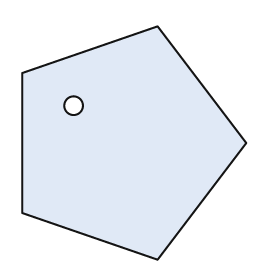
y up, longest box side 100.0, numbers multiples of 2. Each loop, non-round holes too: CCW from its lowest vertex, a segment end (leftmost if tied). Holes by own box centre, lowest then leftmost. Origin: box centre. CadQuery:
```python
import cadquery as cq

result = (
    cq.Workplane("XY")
    .moveTo(10.0, -50.0)
    .lineTo(48.0, 0.0)
    .lineTo(10.0, 50.0)
    .lineTo(-48.0, 30.0)
    .lineTo(-48.0, -30.0)
    .close()
    .moveTo(-26.0, 16.0)
    .circle(4.0)
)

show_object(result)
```